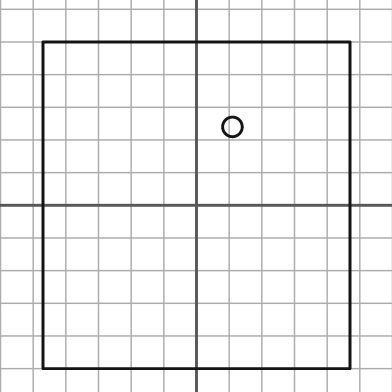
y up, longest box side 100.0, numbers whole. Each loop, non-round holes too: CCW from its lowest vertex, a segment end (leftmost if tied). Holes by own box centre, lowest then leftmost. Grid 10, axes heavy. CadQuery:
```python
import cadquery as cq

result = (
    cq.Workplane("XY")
    .moveTo(-47.0, -50.0)
    .lineTo(47.0, -50.0)
    .lineTo(47.0, 50.0)
    .lineTo(-47.0, 50.0)
    .close()
    .moveTo(11.0, 24.0)
    .circle(3.0)
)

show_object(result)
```